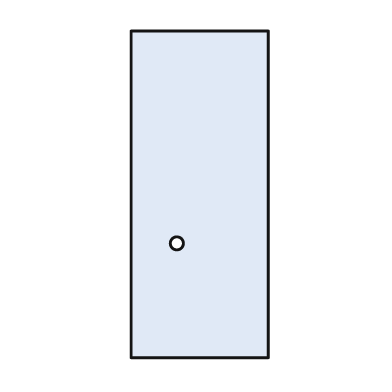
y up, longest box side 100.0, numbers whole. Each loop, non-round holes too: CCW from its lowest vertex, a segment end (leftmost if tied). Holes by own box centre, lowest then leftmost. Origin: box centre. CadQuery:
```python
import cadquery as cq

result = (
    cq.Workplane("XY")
    .moveTo(-21.0, -50.0)
    .lineTo(21.0, -50.0)
    .lineTo(21.0, 50.0)
    .lineTo(-21.0, 50.0)
    .close()
    .moveTo(-7.0, -15.0)
    .circle(2.0)
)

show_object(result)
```